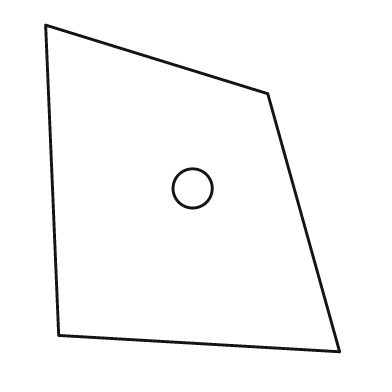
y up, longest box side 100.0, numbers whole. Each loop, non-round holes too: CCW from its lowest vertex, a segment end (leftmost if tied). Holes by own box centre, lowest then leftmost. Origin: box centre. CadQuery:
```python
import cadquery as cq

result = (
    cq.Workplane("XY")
    .moveTo(45.0, -50.0)
    .lineTo(23.0, 29.0)
    .lineTo(-45.0, 50.0)
    .lineTo(-41.0, -45.0)
    .close()
    .moveTo(0.0, 0.0)
    .circle(6.0)
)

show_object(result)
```